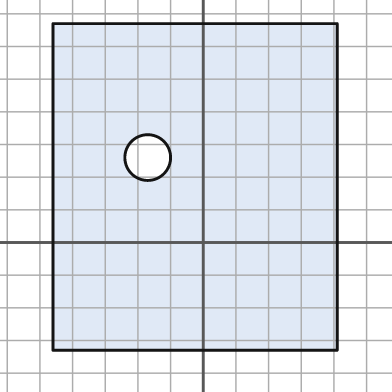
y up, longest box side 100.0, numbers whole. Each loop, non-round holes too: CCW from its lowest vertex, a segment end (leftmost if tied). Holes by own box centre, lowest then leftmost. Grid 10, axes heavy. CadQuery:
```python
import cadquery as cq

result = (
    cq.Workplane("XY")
    .moveTo(-46.0, -33.0)
    .lineTo(41.0, -33.0)
    .lineTo(41.0, 67.0)
    .lineTo(-46.0, 67.0)
    .close()
    .moveTo(-17.0, 26.0)
    .circle(7.0)
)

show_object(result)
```